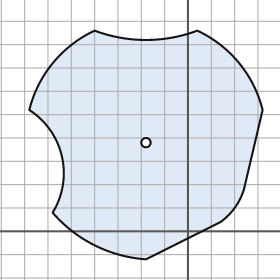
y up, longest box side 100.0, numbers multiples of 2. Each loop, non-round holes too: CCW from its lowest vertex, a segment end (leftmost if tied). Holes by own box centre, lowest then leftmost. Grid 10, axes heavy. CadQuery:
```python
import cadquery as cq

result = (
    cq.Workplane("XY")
    .moveTo(-18.0, -12.0)
    .lineTo(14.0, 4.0)
    .threePointArc((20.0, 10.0), (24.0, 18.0))
    .lineTo(32.0, 52.0)
    .threePointArc((22.0, 72.0), (4.0, 86.0))
    .threePointArc((-18.0, 82.0), (-40.0, 86.0))
    .threePointArc((-58.0, 72.0), (-68.0, 52.0))
    .threePointArc((-54.0, 32.0), (-58.0, 8.0))
    .threePointArc((-40.0, -6.0), (-18.0, -12.0))
    .close()
    .moveTo(-18.0, 38.0)
    .circle(2.0)
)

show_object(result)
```